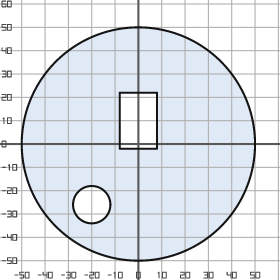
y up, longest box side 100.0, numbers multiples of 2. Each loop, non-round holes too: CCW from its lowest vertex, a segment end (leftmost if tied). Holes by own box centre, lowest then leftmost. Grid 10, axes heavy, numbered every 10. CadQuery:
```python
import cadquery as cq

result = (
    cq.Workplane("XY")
    .moveTo(0.0, 0.0)
    .circle(50.0)
    .moveTo(-20.0, -26.0)
    .circle(8.0)
    .moveTo(-8.0, -2.0)
    .lineTo(8.0, -2.0)
    .lineTo(8.0, 22.0)
    .lineTo(-8.0, 22.0)
    .close()
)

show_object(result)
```